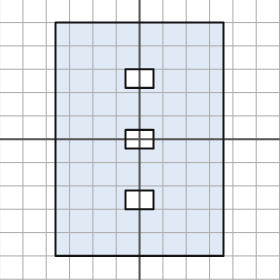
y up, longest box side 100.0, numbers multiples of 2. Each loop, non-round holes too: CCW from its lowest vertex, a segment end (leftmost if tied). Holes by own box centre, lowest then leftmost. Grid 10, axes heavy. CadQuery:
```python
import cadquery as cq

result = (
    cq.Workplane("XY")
    .moveTo(-36.0, -50.0)
    .lineTo(36.0, -50.0)
    .lineTo(36.0, 50.0)
    .lineTo(-36.0, 50.0)
    .close()
    .moveTo(-6.0, -30.0)
    .lineTo(6.0, -30.0)
    .lineTo(6.0, -22.0)
    .lineTo(-6.0, -22.0)
    .close()
    .moveTo(-6.0, -4.0)
    .lineTo(6.0, -4.0)
    .lineTo(6.0, 4.0)
    .lineTo(-6.0, 4.0)
    .close()
    .moveTo(-6.0, 22.0)
    .lineTo(6.0, 22.0)
    .lineTo(6.0, 30.0)
    .lineTo(-6.0, 30.0)
    .close()
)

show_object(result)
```